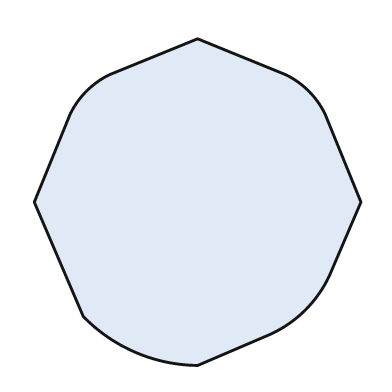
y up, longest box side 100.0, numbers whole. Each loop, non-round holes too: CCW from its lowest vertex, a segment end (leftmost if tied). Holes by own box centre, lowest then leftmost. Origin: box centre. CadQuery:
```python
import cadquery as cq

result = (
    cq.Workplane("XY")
    .moveTo(0.0, -50.0)
    .lineTo(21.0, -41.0)
    .threePointArc((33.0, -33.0), (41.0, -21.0))
    .lineTo(50.0, 0.0)
    .lineTo(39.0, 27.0)
    .threePointArc((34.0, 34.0), (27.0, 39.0))
    .lineTo(0.0, 50.0)
    .lineTo(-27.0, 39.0)
    .threePointArc((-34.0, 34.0), (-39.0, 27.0))
    .lineTo(-50.0, 0.0)
    .lineTo(-35.0, -35.0)
    .threePointArc((-19.0, -46.0), (0.0, -50.0))
    .close()
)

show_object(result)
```